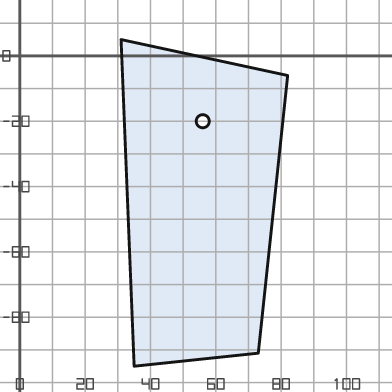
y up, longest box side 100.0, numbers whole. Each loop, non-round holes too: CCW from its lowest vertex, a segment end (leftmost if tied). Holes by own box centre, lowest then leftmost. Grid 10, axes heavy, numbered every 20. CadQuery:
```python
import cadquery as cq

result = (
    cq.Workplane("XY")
    .moveTo(35.0, -95.0)
    .lineTo(73.0, -91.0)
    .lineTo(82.0, -6.0)
    .lineTo(31.0, 5.0)
    .close()
    .moveTo(56.0, -20.0)
    .circle(2.0)
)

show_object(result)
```